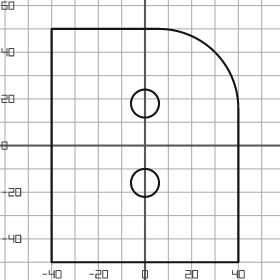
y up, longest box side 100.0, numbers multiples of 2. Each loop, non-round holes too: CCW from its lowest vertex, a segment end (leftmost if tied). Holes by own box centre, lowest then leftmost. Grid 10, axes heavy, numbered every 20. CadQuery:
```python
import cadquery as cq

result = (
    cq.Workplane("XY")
    .moveTo(-40.0, -50.0)
    .lineTo(40.0, -50.0)
    .lineTo(40.0, 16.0)
    .threePointArc((30.0, 40.0), (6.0, 50.0))
    .lineTo(-40.0, 50.0)
    .close()
    .moveTo(0.0, -16.0)
    .circle(6.0)
    .moveTo(0.0, 18.0)
    .circle(6.0)
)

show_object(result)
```